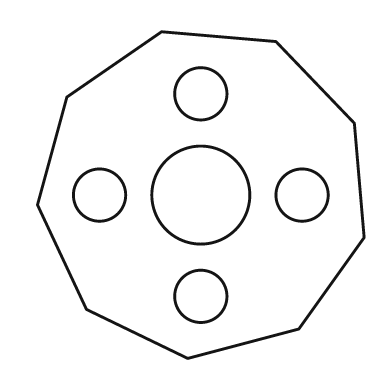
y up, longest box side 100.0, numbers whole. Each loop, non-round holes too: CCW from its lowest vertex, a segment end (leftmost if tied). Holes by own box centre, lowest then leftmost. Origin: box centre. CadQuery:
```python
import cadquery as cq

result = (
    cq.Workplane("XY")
    .moveTo(-4.0, -50.0)
    .lineTo(30.0, -41.0)
    .lineTo(50.0, -13.0)
    .lineTo(47.0, 22.0)
    .lineTo(23.0, 47.0)
    .lineTo(-12.0, 50.0)
    .lineTo(-41.0, 30.0)
    .lineTo(-50.0, -3.0)
    .lineTo(-35.0, -35.0)
    .close()
    .moveTo(0.0, -31.0)
    .circle(8.0)
    .moveTo(-31.0, 0.0)
    .circle(8.0)
    .moveTo(0.0, 0.0)
    .circle(15.0)
    .moveTo(31.0, 0.0)
    .circle(8.0)
    .moveTo(0.0, 31.0)
    .circle(8.0)
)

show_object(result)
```